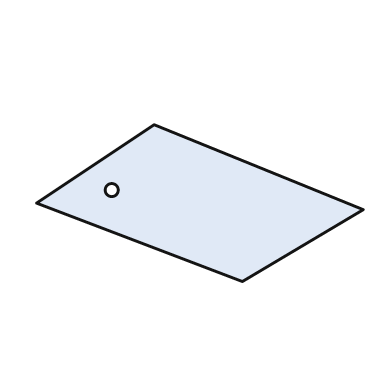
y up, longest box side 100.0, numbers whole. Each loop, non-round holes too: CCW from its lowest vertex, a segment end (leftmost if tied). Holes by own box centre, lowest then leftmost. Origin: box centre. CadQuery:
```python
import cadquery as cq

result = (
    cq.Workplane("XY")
    .moveTo(13.0, -24.0)
    .lineTo(50.0, -2.0)
    .lineTo(-14.0, 24.0)
    .lineTo(-50.0, 0.0)
    .close()
    .moveTo(-27.0, 4.0)
    .circle(2.0)
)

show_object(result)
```